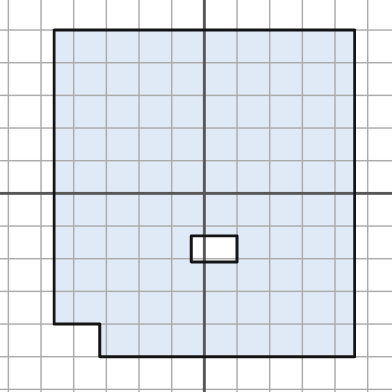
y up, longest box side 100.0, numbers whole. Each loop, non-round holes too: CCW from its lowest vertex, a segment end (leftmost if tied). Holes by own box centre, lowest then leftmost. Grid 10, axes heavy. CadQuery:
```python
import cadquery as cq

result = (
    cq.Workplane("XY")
    .moveTo(-32.0, -50.0)
    .lineTo(46.0, -50.0)
    .lineTo(46.0, 50.0)
    .lineTo(-46.0, 50.0)
    .lineTo(-46.0, -40.0)
    .lineTo(-32.0, -40.0)
    .close()
    .moveTo(-4.0, -21.0)
    .lineTo(10.0, -21.0)
    .lineTo(10.0, -13.0)
    .lineTo(-4.0, -13.0)
    .close()
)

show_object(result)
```